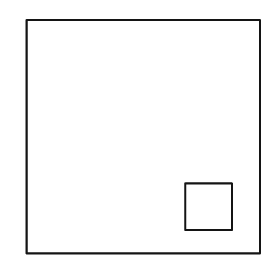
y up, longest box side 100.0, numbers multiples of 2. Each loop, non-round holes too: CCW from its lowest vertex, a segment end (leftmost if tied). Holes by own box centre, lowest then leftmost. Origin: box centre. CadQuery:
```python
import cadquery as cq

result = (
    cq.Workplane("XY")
    .moveTo(-50.0, -50.0)
    .lineTo(50.0, -50.0)
    .lineTo(50.0, 50.0)
    .lineTo(-50.0, 50.0)
    .close()
    .moveTo(18.0, -40.0)
    .lineTo(38.0, -40.0)
    .lineTo(38.0, -20.0)
    .lineTo(18.0, -20.0)
    .close()
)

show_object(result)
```